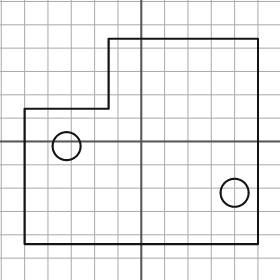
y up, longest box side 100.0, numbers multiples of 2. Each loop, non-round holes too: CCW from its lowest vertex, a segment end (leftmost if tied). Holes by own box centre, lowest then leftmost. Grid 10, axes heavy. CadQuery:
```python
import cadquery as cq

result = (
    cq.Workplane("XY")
    .moveTo(-50.0, -44.0)
    .lineTo(50.0, -44.0)
    .lineTo(50.0, 44.0)
    .lineTo(-14.0, 44.0)
    .lineTo(-14.0, 14.0)
    .lineTo(-50.0, 14.0)
    .close()
    .moveTo(40.0, -22.0)
    .circle(6.0)
    .moveTo(-32.0, -2.0)
    .circle(6.0)
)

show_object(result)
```